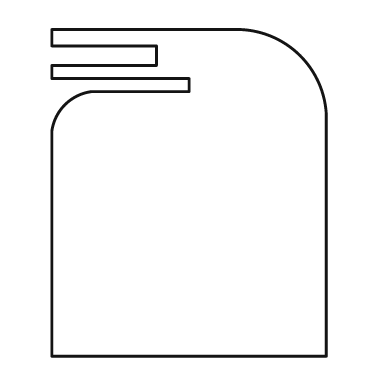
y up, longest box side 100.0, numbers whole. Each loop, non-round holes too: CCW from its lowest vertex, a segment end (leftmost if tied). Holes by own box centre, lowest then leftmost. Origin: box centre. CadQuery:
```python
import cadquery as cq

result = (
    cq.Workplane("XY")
    .moveTo(-42.0, -50.0)
    .lineTo(42.0, -50.0)
    .lineTo(42.0, 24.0)
    .threePointArc((34.0, 42.0), (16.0, 50.0))
    .lineTo(-42.0, 50.0)
    .lineTo(-42.0, 45.0)
    .lineTo(-10.0, 45.0)
    .lineTo(-10.0, 39.0)
    .lineTo(-42.0, 39.0)
    .lineTo(-42.0, 35.0)
    .lineTo(0.0, 35.0)
    .lineTo(0.0, 31.0)
    .lineTo(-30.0, 31.0)
    .threePointArc((-38.0, 27.0), (-42.0, 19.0))
    .close()
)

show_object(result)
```